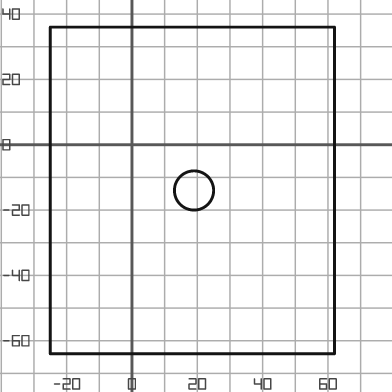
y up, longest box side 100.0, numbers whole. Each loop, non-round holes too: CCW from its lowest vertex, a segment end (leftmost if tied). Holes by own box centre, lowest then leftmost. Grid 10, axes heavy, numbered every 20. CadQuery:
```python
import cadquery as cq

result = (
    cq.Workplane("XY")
    .moveTo(-25.0, -64.0)
    .lineTo(62.0, -64.0)
    .lineTo(62.0, 36.0)
    .lineTo(-25.0, 36.0)
    .close()
    .moveTo(19.0, -14.0)
    .circle(6.0)
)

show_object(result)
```